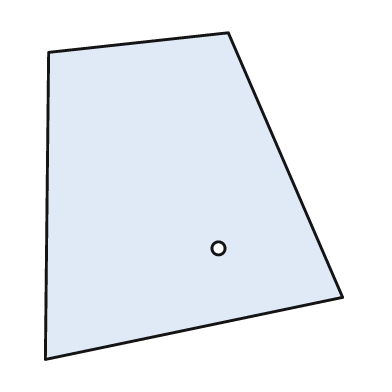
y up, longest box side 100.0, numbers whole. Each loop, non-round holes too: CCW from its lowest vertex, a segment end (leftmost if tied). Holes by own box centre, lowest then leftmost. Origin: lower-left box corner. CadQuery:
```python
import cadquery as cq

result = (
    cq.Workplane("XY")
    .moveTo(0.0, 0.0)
    .lineTo(91.0, 19.0)
    .lineTo(56.0, 100.0)
    .lineTo(1.0, 94.0)
    .close()
    .moveTo(53.0, 34.0)
    .circle(2.0)
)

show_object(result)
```